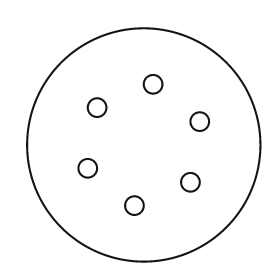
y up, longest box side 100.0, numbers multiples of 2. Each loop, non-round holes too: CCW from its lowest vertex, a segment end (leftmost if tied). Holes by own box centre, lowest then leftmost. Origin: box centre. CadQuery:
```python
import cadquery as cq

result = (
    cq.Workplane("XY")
    .moveTo(0.0, 0.0)
    .circle(50.0)
    .moveTo(-4.0, -26.0)
    .circle(4.0)
    .moveTo(20.0, -16.0)
    .circle(4.0)
    .moveTo(-24.0, -10.0)
    .circle(4.0)
    .moveTo(24.0, 10.0)
    .circle(4.0)
    .moveTo(-20.0, 16.0)
    .circle(4.0)
    .moveTo(4.0, 26.0)
    .circle(4.0)
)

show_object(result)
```